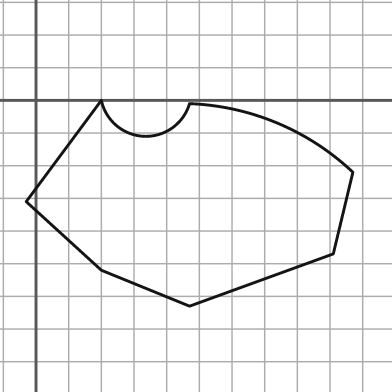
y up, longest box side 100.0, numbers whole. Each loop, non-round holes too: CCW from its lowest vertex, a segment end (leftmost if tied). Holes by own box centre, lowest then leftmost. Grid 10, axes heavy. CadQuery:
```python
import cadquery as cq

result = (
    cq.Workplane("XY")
    .moveTo(47.0, -63.0)
    .lineTo(91.0, -47.0)
    .lineTo(97.0, -22.0)
    .threePointArc((74.0, -7.0), (47.0, -1.0))
    .threePointArc((33.0, -11.0), (20.0, 0.0))
    .lineTo(-3.0, -31.0)
    .lineTo(20.0, -52.0)
    .close()
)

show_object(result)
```